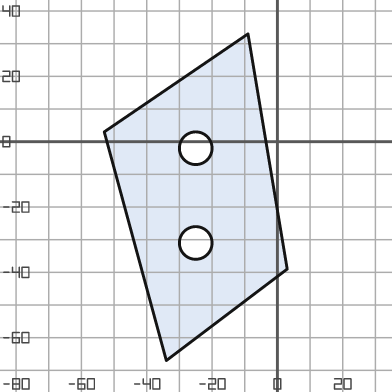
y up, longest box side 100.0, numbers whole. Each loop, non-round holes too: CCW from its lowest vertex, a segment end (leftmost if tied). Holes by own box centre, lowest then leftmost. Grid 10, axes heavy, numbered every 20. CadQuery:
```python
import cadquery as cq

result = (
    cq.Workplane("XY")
    .moveTo(-34.0, -67.0)
    .lineTo(3.0, -39.0)
    .lineTo(-9.0, 33.0)
    .lineTo(-53.0, 3.0)
    .close()
    .moveTo(-25.0, -31.0)
    .circle(5.0)
    .moveTo(-25.0, -2.0)
    .circle(5.0)
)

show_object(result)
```